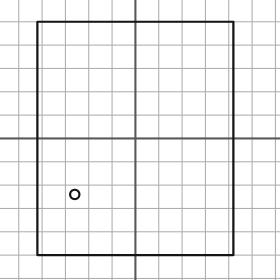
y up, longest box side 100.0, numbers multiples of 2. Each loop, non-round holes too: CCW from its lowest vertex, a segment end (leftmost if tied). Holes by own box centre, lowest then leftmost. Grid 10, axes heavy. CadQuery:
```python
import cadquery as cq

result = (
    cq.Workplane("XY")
    .moveTo(-42.0, -50.0)
    .lineTo(42.0, -50.0)
    .lineTo(42.0, 50.0)
    .lineTo(-42.0, 50.0)
    .close()
    .moveTo(-26.0, -24.0)
    .circle(2.0)
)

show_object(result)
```